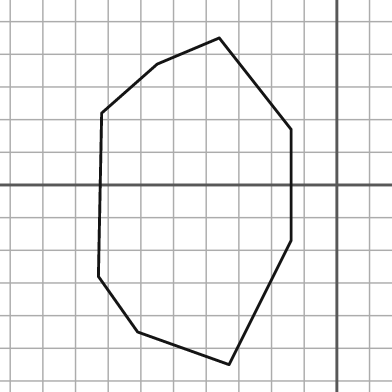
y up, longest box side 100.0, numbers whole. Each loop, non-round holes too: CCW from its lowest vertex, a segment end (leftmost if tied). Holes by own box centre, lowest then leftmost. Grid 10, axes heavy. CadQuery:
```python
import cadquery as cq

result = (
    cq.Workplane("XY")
    .moveTo(-33.0, -55.0)
    .lineTo(-14.0, -17.0)
    .lineTo(-14.0, 17.0)
    .lineTo(-36.0, 45.0)
    .lineTo(-55.0, 37.0)
    .lineTo(-72.0, 22.0)
    .lineTo(-73.0, -28.0)
    .lineTo(-61.0, -45.0)
    .close()
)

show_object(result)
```